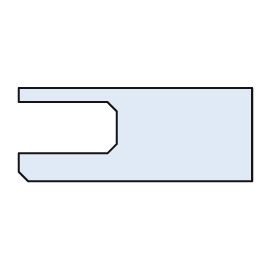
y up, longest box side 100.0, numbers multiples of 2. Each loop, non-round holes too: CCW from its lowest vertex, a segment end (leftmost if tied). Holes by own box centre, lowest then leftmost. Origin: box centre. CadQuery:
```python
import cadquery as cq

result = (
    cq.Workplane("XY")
    .moveTo(-46.0, -20.0)
    .lineTo(50.0, -20.0)
    .lineTo(50.0, 20.0)
    .lineTo(-50.0, 20.0)
    .lineTo(-50.0, 14.0)
    .lineTo(-12.0, 14.0)
    .lineTo(-8.0, 10.0)
    .lineTo(-8.0, -4.0)
    .lineTo(-12.0, -8.0)
    .lineTo(-50.0, -8.0)
    .lineTo(-50.0, -16.0)
    .close()
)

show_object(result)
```